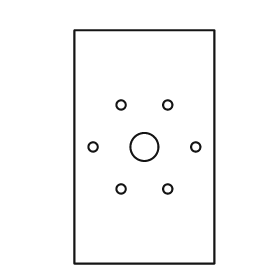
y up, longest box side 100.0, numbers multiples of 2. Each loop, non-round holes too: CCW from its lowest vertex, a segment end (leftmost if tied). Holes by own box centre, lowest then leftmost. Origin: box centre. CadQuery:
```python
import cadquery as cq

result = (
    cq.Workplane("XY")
    .moveTo(-30.0, -50.0)
    .lineTo(30.0, -50.0)
    .lineTo(30.0, 50.0)
    .lineTo(-30.0, 50.0)
    .close()
    .moveTo(-10.0, -18.0)
    .circle(2.0)
    .moveTo(10.0, -18.0)
    .circle(2.0)
    .moveTo(-22.0, 0.0)
    .circle(2.0)
    .moveTo(0.0, 0.0)
    .circle(6.0)
    .moveTo(22.0, 0.0)
    .circle(2.0)
    .moveTo(-10.0, 18.0)
    .circle(2.0)
    .moveTo(10.0, 18.0)
    .circle(2.0)
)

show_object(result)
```